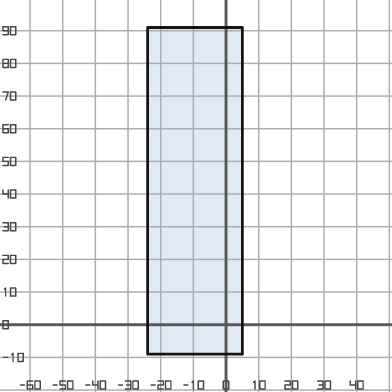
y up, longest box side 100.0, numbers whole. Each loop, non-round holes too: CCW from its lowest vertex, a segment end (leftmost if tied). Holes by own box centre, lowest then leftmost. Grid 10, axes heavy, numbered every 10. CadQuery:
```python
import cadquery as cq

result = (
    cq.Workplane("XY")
    .moveTo(-24.0, -9.0)
    .lineTo(5.0, -9.0)
    .lineTo(5.0, 91.0)
    .lineTo(-24.0, 91.0)
    .close()
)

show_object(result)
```